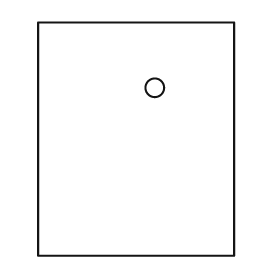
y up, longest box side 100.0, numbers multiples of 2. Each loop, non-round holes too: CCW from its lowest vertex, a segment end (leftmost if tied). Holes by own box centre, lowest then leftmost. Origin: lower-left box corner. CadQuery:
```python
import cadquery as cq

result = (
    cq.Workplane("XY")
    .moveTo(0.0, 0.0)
    .lineTo(84.0, 0.0)
    .lineTo(84.0, 100.0)
    .lineTo(0.0, 100.0)
    .close()
    .moveTo(50.0, 72.0)
    .circle(4.0)
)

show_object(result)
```